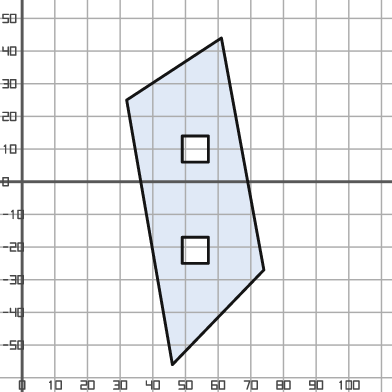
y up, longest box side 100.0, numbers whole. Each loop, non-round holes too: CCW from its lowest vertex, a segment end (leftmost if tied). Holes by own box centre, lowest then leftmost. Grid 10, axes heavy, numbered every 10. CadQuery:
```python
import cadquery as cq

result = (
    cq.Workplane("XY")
    .moveTo(46.0, -56.0)
    .lineTo(74.0, -27.0)
    .lineTo(61.0, 44.0)
    .lineTo(32.0, 25.0)
    .close()
    .moveTo(49.0, -25.0)
    .lineTo(57.0, -25.0)
    .lineTo(57.0, -17.0)
    .lineTo(49.0, -17.0)
    .close()
    .moveTo(49.0, 6.0)
    .lineTo(57.0, 6.0)
    .lineTo(57.0, 14.0)
    .lineTo(49.0, 14.0)
    .close()
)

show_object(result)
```